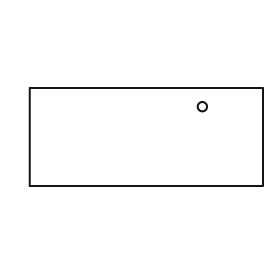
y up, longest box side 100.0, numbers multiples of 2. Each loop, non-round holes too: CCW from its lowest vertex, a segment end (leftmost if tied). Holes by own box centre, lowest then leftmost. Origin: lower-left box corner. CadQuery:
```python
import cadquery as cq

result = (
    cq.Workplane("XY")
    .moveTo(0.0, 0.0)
    .lineTo(100.0, 0.0)
    .lineTo(100.0, 42.0)
    .lineTo(0.0, 42.0)
    .close()
    .moveTo(74.0, 34.0)
    .circle(2.0)
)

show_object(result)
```